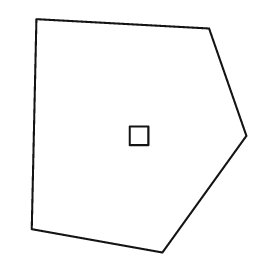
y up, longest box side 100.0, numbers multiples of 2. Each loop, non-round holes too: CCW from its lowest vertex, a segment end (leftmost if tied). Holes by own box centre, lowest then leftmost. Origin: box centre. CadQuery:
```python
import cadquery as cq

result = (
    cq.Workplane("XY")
    .moveTo(10.0, -50.0)
    .lineTo(46.0, 0.0)
    .lineTo(30.0, 46.0)
    .lineTo(-44.0, 50.0)
    .lineTo(-46.0, -40.0)
    .close()
    .moveTo(-4.0, -4.0)
    .lineTo(4.0, -4.0)
    .lineTo(4.0, 4.0)
    .lineTo(-4.0, 4.0)
    .close()
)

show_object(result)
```